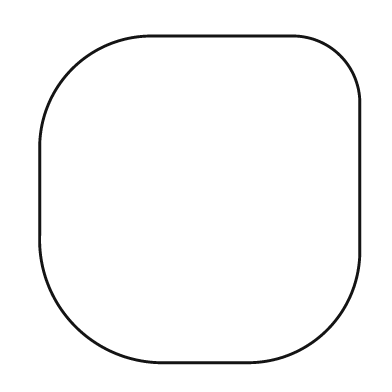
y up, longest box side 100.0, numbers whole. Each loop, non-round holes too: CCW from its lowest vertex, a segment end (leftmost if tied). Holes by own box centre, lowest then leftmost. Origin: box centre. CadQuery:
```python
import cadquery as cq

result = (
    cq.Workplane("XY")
    .moveTo(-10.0, -50.0)
    .lineTo(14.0, -50.0)
    .threePointArc((39.0, -40.0), (49.0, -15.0))
    .lineTo(49.0, 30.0)
    .threePointArc((43.0, 44.0), (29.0, 50.0))
    .lineTo(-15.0, 50.0)
    .threePointArc((-39.0, 40.0), (-49.0, 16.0))
    .lineTo(-49.0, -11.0)
    .threePointArc((-38.0, -39.0), (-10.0, -50.0))
    .close()
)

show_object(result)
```